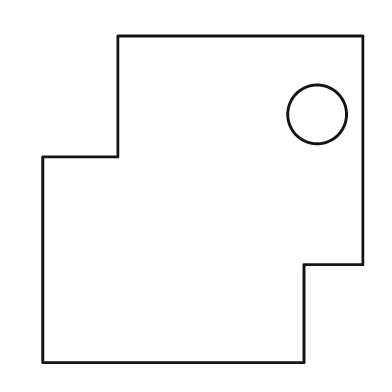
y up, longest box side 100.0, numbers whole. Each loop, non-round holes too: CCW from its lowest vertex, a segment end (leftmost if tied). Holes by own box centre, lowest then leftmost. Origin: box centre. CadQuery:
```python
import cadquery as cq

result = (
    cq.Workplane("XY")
    .moveTo(-49.0, -50.0)
    .lineTo(31.0, -50.0)
    .lineTo(31.0, -20.0)
    .lineTo(49.0, -20.0)
    .lineTo(49.0, 50.0)
    .lineTo(-26.0, 50.0)
    .lineTo(-26.0, 13.0)
    .lineTo(-49.0, 13.0)
    .close()
    .moveTo(35.0, 26.0)
    .circle(9.0)
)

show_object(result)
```